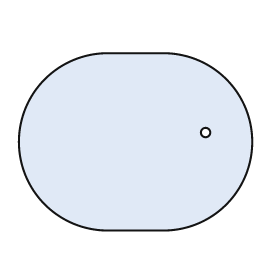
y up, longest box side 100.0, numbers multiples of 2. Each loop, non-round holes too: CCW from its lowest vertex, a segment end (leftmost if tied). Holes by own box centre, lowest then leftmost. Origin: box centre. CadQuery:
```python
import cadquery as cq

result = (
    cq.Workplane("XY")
    .moveTo(-12.0, -38.0)
    .lineTo(12.0, -38.0)
    .threePointArc((50.0, 0.0), (12.0, 38.0))
    .lineTo(-12.0, 38.0)
    .threePointArc((-50.0, 0.0), (-12.0, -38.0))
    .close()
    .moveTo(30.0, 4.0)
    .circle(2.0)
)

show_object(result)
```